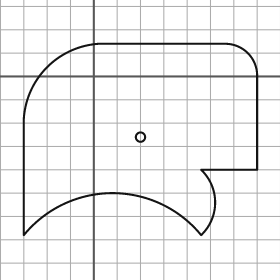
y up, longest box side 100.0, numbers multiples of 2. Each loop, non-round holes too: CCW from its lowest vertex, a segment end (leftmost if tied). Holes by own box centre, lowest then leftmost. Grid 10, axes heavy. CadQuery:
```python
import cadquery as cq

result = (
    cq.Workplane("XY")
    .moveTo(-30.0, -68.0)
    .threePointArc((8.0, -50.0), (46.0, -68.0))
    .threePointArc((52.0, -54.0), (46.0, -40.0))
    .lineTo(70.0, -40.0)
    .lineTo(70.0, 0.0)
    .threePointArc((66.0, 10.0), (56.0, 14.0))
    .lineTo(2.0, 14.0)
    .threePointArc((-20.0, 4.0), (-30.0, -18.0))
    .close()
    .moveTo(20.0, -26.0)
    .circle(2.0)
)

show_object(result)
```